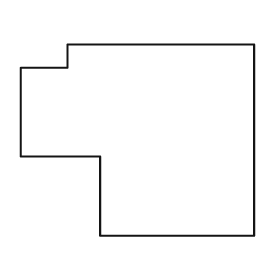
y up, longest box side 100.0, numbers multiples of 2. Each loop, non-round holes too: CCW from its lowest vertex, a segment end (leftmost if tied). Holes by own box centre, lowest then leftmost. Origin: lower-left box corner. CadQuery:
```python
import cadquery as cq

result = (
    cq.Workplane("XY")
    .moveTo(34.0, 0.0)
    .lineTo(100.0, 0.0)
    .lineTo(100.0, 82.0)
    .lineTo(20.0, 82.0)
    .lineTo(20.0, 72.0)
    .lineTo(0.0, 72.0)
    .lineTo(0.0, 34.0)
    .lineTo(34.0, 34.0)
    .close()
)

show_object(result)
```